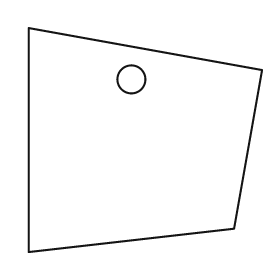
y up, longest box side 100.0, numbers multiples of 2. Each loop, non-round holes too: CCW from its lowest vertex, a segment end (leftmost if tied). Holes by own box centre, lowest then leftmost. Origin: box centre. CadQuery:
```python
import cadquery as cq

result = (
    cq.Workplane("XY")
    .moveTo(-50.0, -48.0)
    .lineTo(38.0, -38.0)
    .lineTo(50.0, 30.0)
    .lineTo(-50.0, 48.0)
    .close()
    .moveTo(-6.0, 26.0)
    .circle(6.0)
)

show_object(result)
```